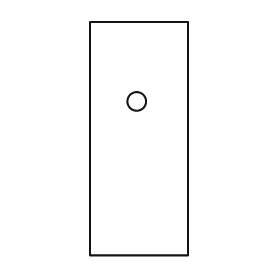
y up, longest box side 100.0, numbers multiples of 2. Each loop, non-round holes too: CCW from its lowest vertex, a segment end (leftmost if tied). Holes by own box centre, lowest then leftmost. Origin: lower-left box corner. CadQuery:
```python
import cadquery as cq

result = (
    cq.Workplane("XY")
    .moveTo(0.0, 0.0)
    .lineTo(42.0, 0.0)
    .lineTo(42.0, 100.0)
    .lineTo(0.0, 100.0)
    .close()
    .moveTo(20.0, 66.0)
    .circle(4.0)
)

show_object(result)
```